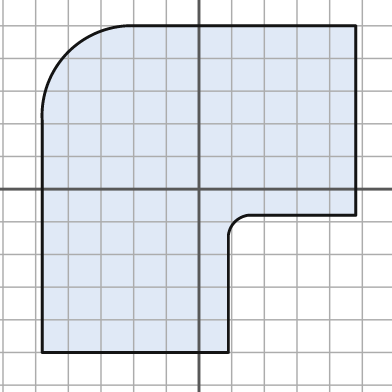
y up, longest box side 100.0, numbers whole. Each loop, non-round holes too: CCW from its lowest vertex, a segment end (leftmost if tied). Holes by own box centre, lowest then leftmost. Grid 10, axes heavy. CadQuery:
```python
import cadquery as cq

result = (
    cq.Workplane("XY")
    .moveTo(-48.0, -50.0)
    .lineTo(9.0, -50.0)
    .lineTo(9.0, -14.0)
    .threePointArc((11.0, -10.0), (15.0, -8.0))
    .lineTo(48.0, -8.0)
    .lineTo(48.0, 50.0)
    .lineTo(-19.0, 50.0)
    .threePointArc((-40.0, 42.0), (-48.0, 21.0))
    .close()
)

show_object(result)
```